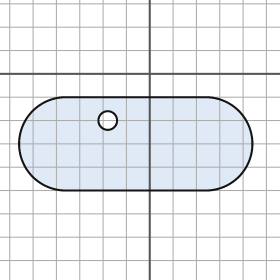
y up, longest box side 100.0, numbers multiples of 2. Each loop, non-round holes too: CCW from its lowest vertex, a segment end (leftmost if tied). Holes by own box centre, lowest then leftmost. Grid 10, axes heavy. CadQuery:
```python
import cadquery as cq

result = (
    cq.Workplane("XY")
    .moveTo(-36.0, -50.0)
    .lineTo(24.0, -50.0)
    .threePointArc((44.0, -30.0), (24.0, -10.0))
    .lineTo(-36.0, -10.0)
    .threePointArc((-56.0, -30.0), (-36.0, -50.0))
    .close()
    .moveTo(-18.0, -20.0)
    .circle(4.0)
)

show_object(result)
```